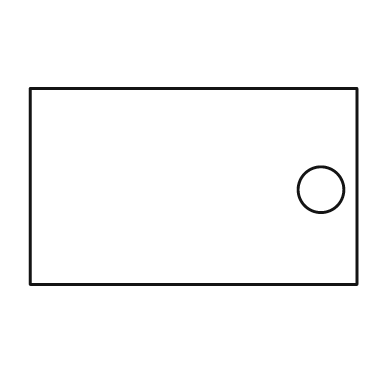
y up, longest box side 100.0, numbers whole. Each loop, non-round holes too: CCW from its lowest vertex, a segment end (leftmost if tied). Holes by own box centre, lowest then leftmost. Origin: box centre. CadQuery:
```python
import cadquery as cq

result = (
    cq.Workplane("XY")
    .moveTo(-50.0, -30.0)
    .lineTo(50.0, -30.0)
    .lineTo(50.0, 30.0)
    .lineTo(-50.0, 30.0)
    .close()
    .moveTo(39.0, -1.0)
    .circle(7.0)
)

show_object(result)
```